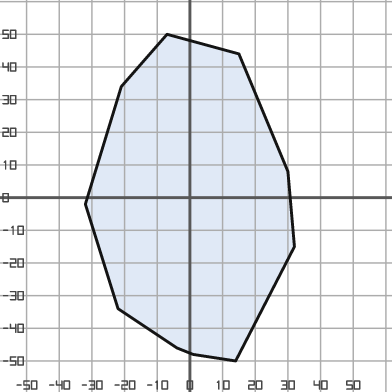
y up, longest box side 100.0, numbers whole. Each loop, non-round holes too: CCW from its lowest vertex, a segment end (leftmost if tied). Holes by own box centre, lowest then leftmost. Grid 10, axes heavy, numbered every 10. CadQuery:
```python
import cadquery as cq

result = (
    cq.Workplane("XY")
    .moveTo(14.0, -50.0)
    .lineTo(32.0, -15.0)
    .lineTo(30.0, 8.0)
    .lineTo(15.0, 44.0)
    .lineTo(-7.0, 50.0)
    .lineTo(-21.0, 34.0)
    .lineTo(-32.0, -2.0)
    .lineTo(-22.0, -34.0)
    .lineTo(-4.0, -46.0)
    .lineTo(1.0, -48.0)
    .close()
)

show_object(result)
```